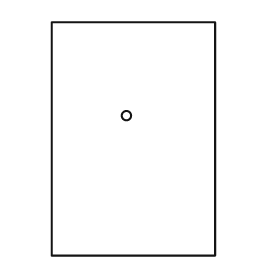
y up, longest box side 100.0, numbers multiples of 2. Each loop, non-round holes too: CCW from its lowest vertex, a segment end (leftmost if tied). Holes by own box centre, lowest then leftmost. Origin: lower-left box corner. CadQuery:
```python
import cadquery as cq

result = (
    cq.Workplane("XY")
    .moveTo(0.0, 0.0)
    .lineTo(70.0, 0.0)
    .lineTo(70.0, 100.0)
    .lineTo(0.0, 100.0)
    .close()
    .moveTo(32.0, 60.0)
    .circle(2.0)
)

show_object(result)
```